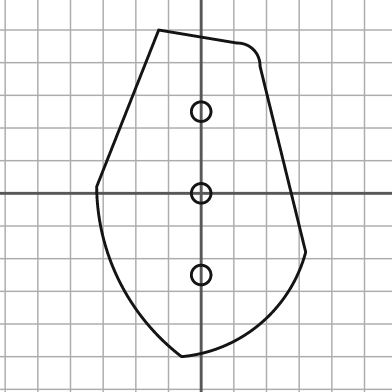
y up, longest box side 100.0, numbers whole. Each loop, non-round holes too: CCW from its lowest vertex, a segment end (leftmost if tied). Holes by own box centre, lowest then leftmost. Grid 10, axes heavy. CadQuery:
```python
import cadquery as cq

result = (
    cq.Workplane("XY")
    .moveTo(-6.0, -50.0)
    .threePointArc((18.0, -40.0), (32.0, -18.0))
    .lineTo(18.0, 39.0)
    .threePointArc((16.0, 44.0), (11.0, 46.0))
    .lineTo(-13.0, 50.0)
    .lineTo(-32.0, 2.0)
    .threePointArc((-25.0, -27.0), (-6.0, -50.0))
    .close()
    .moveTo(0.0, -25.0)
    .circle(3.0)
    .moveTo(0.0, 0.0)
    .circle(3.0)
    .moveTo(0.0, 25.0)
    .circle(3.0)
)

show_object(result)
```